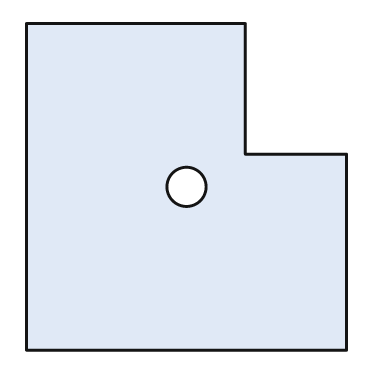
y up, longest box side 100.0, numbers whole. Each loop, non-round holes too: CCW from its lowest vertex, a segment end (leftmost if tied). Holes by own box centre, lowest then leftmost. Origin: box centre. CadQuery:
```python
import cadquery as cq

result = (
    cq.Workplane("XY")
    .moveTo(-49.0, -50.0)
    .lineTo(49.0, -50.0)
    .lineTo(49.0, 10.0)
    .lineTo(18.0, 10.0)
    .lineTo(18.0, 50.0)
    .lineTo(-49.0, 50.0)
    .close()
    .moveTo(0.0, 0.0)
    .circle(6.0)
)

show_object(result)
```